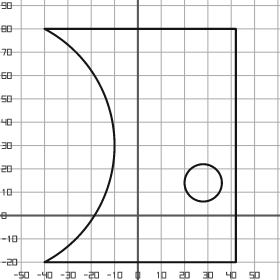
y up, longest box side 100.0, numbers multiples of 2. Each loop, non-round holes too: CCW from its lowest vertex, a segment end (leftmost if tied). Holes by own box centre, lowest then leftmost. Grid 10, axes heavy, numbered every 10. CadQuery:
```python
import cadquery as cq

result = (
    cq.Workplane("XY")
    .moveTo(-40.0, -20.0)
    .lineTo(42.0, -20.0)
    .lineTo(42.0, 80.0)
    .lineTo(-40.0, 80.0)
    .threePointArc((-10.0, 30.0), (-40.0, -20.0))
    .close()
    .moveTo(28.0, 14.0)
    .circle(8.0)
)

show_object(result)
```